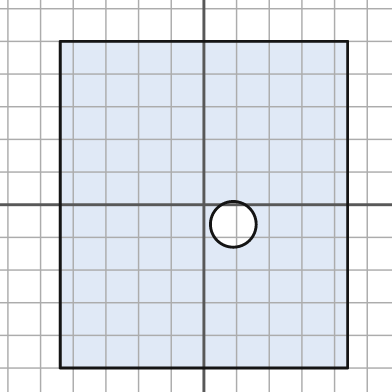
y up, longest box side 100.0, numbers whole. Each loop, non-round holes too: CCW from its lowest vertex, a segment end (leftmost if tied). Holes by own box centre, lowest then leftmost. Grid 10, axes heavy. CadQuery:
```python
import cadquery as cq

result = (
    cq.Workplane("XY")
    .moveTo(-44.0, -50.0)
    .lineTo(44.0, -50.0)
    .lineTo(44.0, 50.0)
    .lineTo(-44.0, 50.0)
    .close()
    .moveTo(9.0, -6.0)
    .circle(7.0)
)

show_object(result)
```